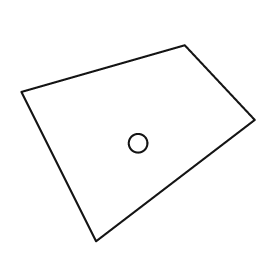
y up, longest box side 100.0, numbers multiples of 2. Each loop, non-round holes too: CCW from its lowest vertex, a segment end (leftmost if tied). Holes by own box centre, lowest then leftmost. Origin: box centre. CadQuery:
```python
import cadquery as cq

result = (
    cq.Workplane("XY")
    .moveTo(-18.0, -42.0)
    .lineTo(50.0, 10.0)
    .lineTo(20.0, 42.0)
    .lineTo(-50.0, 22.0)
    .close()
    .moveTo(0.0, 0.0)
    .circle(4.0)
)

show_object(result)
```